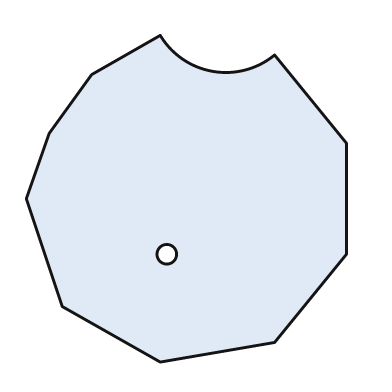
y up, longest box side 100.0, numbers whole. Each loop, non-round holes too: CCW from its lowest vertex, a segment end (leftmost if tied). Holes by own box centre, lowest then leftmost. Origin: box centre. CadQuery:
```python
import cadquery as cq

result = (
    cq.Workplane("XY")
    .moveTo(-8.0, -50.0)
    .lineTo(27.0, -44.0)
    .lineTo(49.0, -17.0)
    .lineTo(49.0, 17.0)
    .lineTo(27.0, 44.0)
    .threePointArc((8.0, 39.0), (-8.0, 50.0))
    .lineTo(-29.0, 38.0)
    .lineTo(-42.0, 20.0)
    .lineTo(-49.0, 0.0)
    .lineTo(-38.0, -33.0)
    .close()
    .moveTo(-6.0, -17.0)
    .circle(3.0)
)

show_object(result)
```